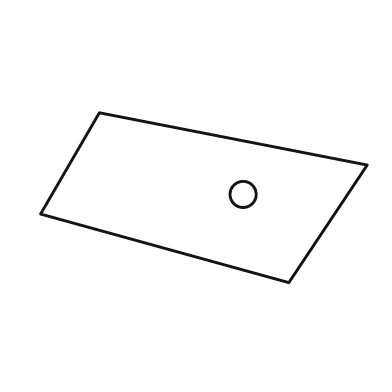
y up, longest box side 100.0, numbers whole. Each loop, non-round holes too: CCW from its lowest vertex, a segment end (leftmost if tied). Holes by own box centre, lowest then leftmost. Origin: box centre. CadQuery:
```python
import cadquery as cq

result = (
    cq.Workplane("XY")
    .moveTo(26.0, -26.0)
    .lineTo(50.0, 10.0)
    .lineTo(-32.0, 26.0)
    .lineTo(-50.0, -5.0)
    .close()
    .moveTo(12.0, 1.0)
    .circle(4.0)
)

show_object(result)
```